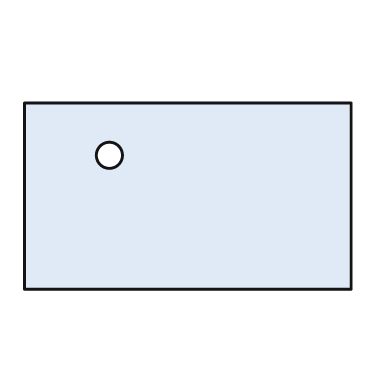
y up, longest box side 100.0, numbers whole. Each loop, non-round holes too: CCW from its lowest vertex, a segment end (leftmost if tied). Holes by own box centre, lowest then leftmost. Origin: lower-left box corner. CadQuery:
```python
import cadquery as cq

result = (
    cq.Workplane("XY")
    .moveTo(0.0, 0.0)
    .lineTo(100.0, 0.0)
    .lineTo(100.0, 57.0)
    .lineTo(0.0, 57.0)
    .close()
    .moveTo(26.0, 41.0)
    .circle(4.0)
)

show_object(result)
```